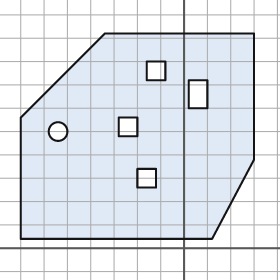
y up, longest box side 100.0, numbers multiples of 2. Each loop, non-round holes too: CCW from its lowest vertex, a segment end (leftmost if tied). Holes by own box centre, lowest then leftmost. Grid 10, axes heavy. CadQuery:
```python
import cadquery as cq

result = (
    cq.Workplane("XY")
    .moveTo(-70.0, 4.0)
    .lineTo(12.0, 4.0)
    .lineTo(30.0, 38.0)
    .lineTo(30.0, 92.0)
    .lineTo(-34.0, 92.0)
    .lineTo(-70.0, 56.0)
    .close()
    .moveTo(-20.0, 26.0)
    .lineTo(-12.0, 26.0)
    .lineTo(-12.0, 34.0)
    .lineTo(-20.0, 34.0)
    .close()
    .moveTo(-54.0, 50.0)
    .circle(4.0)
    .moveTo(-28.0, 48.0)
    .lineTo(-20.0, 48.0)
    .lineTo(-20.0, 56.0)
    .lineTo(-28.0, 56.0)
    .close()
    .moveTo(2.0, 60.0)
    .lineTo(10.0, 60.0)
    .lineTo(10.0, 72.0)
    .lineTo(2.0, 72.0)
    .close()
    .moveTo(-16.0, 72.0)
    .lineTo(-8.0, 72.0)
    .lineTo(-8.0, 80.0)
    .lineTo(-16.0, 80.0)
    .close()
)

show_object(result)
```